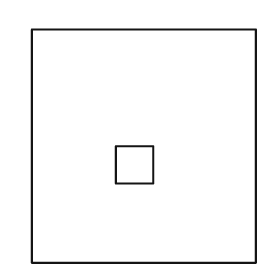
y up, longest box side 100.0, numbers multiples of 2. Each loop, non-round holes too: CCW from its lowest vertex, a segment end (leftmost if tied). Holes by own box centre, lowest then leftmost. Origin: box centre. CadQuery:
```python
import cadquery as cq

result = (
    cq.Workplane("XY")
    .moveTo(-48.0, -50.0)
    .lineTo(48.0, -50.0)
    .lineTo(48.0, 50.0)
    .lineTo(-48.0, 50.0)
    .close()
    .moveTo(-12.0, -16.0)
    .lineTo(4.0, -16.0)
    .lineTo(4.0, 0.0)
    .lineTo(-12.0, 0.0)
    .close()
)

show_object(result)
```